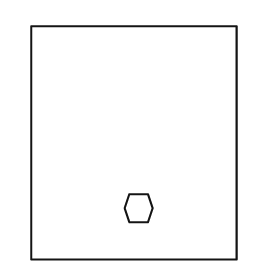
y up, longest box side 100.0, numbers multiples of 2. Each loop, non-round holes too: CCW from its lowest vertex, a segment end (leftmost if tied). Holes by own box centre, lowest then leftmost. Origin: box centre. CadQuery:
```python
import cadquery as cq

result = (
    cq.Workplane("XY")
    .moveTo(-44.0, -50.0)
    .lineTo(44.0, -50.0)
    .lineTo(44.0, 50.0)
    .lineTo(-44.0, 50.0)
    .close()
    .moveTo(-2.0, -34.0)
    .lineTo(6.0, -34.0)
    .lineTo(8.0, -28.0)
    .lineTo(6.0, -22.0)
    .lineTo(-2.0, -22.0)
    .lineTo(-4.0, -28.0)
    .close()
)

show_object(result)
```